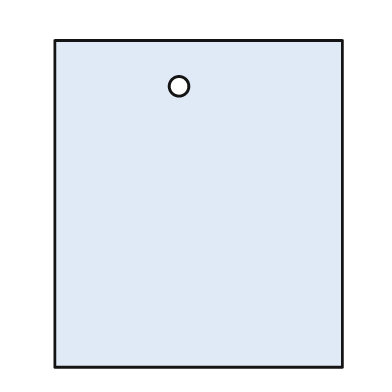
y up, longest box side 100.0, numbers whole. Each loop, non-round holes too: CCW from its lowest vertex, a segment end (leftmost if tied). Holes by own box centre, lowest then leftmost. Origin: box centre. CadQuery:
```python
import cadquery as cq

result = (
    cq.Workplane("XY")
    .moveTo(-44.0, -50.0)
    .lineTo(44.0, -50.0)
    .lineTo(44.0, 50.0)
    .lineTo(-44.0, 50.0)
    .close()
    .moveTo(-6.0, 36.0)
    .circle(3.0)
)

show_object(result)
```